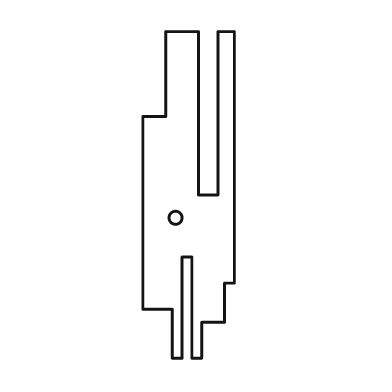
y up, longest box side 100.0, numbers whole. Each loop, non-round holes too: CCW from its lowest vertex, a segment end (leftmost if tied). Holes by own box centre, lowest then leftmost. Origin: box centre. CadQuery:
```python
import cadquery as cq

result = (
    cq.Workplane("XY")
    .moveTo(-5.0, -50.0)
    .lineTo(-2.0, -50.0)
    .lineTo(-2.0, -19.0)
    .lineTo(1.0, -19.0)
    .lineTo(1.0, -50.0)
    .lineTo(4.0, -50.0)
    .lineTo(4.0, -39.0)
    .lineTo(11.0, -39.0)
    .lineTo(11.0, -27.0)
    .lineTo(14.0, -27.0)
    .lineTo(14.0, 50.0)
    .lineTo(9.0, 50.0)
    .lineTo(9.0, 0.0)
    .lineTo(3.0, 0.0)
    .lineTo(3.0, 50.0)
    .lineTo(-7.0, 50.0)
    .lineTo(-7.0, 24.0)
    .lineTo(-14.0, 24.0)
    .lineTo(-14.0, -35.0)
    .lineTo(-5.0, -35.0)
    .close()
    .moveTo(-4.0, -7.0)
    .circle(2.0)
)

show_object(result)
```